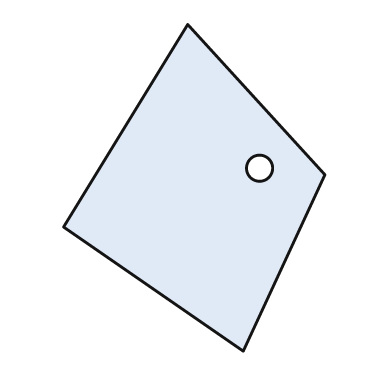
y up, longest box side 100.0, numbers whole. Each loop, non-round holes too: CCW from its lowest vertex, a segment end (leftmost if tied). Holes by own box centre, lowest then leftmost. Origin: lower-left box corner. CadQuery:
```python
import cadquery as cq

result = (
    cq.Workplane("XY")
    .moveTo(55.0, 0.0)
    .lineTo(80.0, 54.0)
    .lineTo(38.0, 100.0)
    .lineTo(0.0, 38.0)
    .close()
    .moveTo(60.0, 56.0)
    .circle(4.0)
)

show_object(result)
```